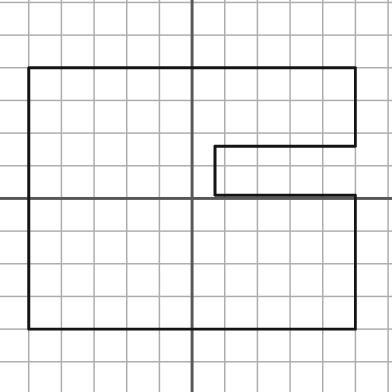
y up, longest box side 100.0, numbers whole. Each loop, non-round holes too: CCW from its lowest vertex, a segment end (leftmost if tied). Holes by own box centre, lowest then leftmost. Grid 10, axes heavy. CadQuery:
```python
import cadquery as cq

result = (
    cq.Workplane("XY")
    .moveTo(-50.0, -40.0)
    .lineTo(50.0, -40.0)
    .lineTo(50.0, 1.0)
    .lineTo(7.0, 1.0)
    .lineTo(7.0, 16.0)
    .lineTo(50.0, 16.0)
    .lineTo(50.0, 40.0)
    .lineTo(-50.0, 40.0)
    .close()
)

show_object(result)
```